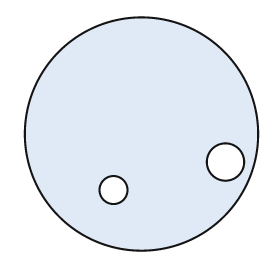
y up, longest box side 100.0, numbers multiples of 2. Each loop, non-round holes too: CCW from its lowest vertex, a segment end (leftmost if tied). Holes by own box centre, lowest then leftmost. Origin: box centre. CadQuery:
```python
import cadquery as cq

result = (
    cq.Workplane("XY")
    .moveTo(0.0, 0.0)
    .circle(50.0)
    .moveTo(-12.0, -24.0)
    .circle(6.0)
    .moveTo(36.0, -12.0)
    .circle(8.0)
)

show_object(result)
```